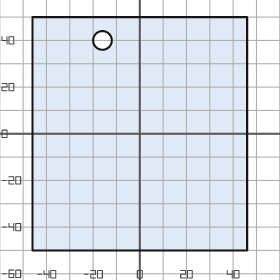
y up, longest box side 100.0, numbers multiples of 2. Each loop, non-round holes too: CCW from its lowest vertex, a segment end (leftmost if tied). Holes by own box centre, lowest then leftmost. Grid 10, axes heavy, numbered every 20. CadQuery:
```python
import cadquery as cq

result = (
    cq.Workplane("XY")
    .moveTo(-46.0, -50.0)
    .lineTo(46.0, -50.0)
    .lineTo(46.0, 50.0)
    .lineTo(-46.0, 50.0)
    .close()
    .moveTo(-16.0, 40.0)
    .circle(4.0)
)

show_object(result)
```